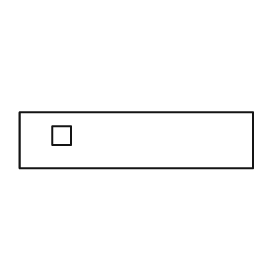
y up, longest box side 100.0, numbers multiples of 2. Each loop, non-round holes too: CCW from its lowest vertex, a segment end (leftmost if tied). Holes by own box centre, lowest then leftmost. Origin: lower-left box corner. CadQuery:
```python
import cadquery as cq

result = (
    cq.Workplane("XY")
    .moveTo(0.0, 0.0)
    .lineTo(100.0, 0.0)
    .lineTo(100.0, 24.0)
    .lineTo(0.0, 24.0)
    .close()
    .moveTo(14.0, 10.0)
    .lineTo(22.0, 10.0)
    .lineTo(22.0, 18.0)
    .lineTo(14.0, 18.0)
    .close()
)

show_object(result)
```